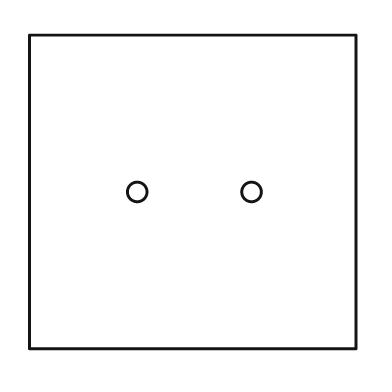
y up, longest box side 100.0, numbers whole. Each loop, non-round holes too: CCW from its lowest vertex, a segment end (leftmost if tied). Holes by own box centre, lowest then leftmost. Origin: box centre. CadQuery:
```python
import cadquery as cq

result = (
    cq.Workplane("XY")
    .moveTo(-50.0, -48.0)
    .lineTo(50.0, -48.0)
    .lineTo(50.0, 48.0)
    .lineTo(-50.0, 48.0)
    .close()
    .moveTo(-17.0, 0.0)
    .circle(3.0)
    .moveTo(18.0, 0.0)
    .circle(3.0)
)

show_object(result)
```